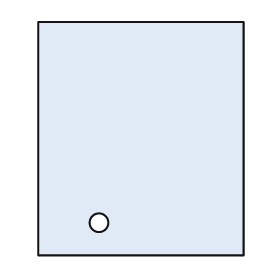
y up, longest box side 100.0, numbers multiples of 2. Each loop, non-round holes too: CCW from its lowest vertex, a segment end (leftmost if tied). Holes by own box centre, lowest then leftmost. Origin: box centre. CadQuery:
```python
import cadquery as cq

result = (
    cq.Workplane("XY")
    .moveTo(-44.0, -50.0)
    .lineTo(44.0, -50.0)
    .lineTo(44.0, 50.0)
    .lineTo(-44.0, 50.0)
    .close()
    .moveTo(-18.0, -36.0)
    .circle(4.0)
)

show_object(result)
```